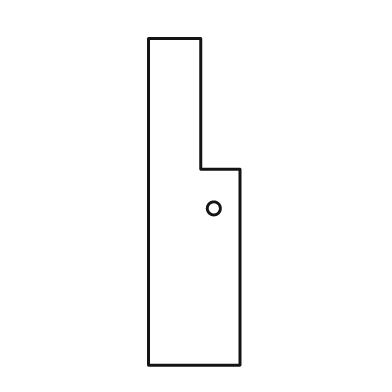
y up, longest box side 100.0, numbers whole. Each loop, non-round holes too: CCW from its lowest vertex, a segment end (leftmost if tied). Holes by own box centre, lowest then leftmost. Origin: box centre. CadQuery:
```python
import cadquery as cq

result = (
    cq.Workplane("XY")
    .moveTo(-14.0, -50.0)
    .lineTo(14.0, -50.0)
    .lineTo(14.0, 10.0)
    .lineTo(2.0, 10.0)
    .lineTo(2.0, 50.0)
    .lineTo(-14.0, 50.0)
    .close()
    .moveTo(6.0, -2.0)
    .circle(2.0)
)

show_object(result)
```